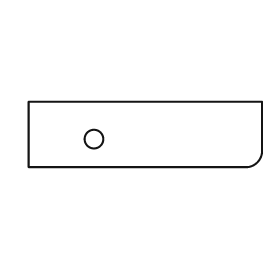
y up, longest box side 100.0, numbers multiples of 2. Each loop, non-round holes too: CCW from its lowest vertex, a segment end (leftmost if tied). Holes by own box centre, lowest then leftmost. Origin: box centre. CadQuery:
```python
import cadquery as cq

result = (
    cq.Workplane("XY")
    .moveTo(-50.0, -14.0)
    .lineTo(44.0, -14.0)
    .threePointArc((48.0, -12.0), (50.0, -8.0))
    .lineTo(50.0, 14.0)
    .lineTo(-50.0, 14.0)
    .close()
    .moveTo(-22.0, -2.0)
    .circle(4.0)
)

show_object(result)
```